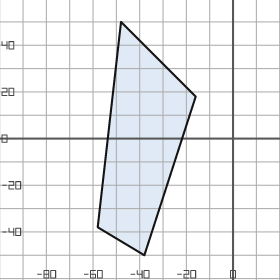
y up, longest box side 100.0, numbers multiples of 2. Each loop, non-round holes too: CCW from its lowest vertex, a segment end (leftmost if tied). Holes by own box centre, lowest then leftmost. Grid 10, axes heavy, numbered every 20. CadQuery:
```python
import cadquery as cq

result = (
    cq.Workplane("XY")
    .moveTo(-38.0, -50.0)
    .lineTo(-16.0, 18.0)
    .lineTo(-48.0, 50.0)
    .lineTo(-58.0, -38.0)
    .close()
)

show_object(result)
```